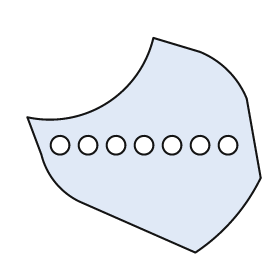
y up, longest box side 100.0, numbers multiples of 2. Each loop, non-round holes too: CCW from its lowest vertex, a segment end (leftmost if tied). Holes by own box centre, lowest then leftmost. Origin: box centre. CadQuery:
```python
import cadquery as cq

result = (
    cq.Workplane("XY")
    .moveTo(22.0, -46.0)
    .threePointArc((38.0, -32.0), (50.0, -14.0))
    .lineTo(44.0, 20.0)
    .threePointArc((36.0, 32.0), (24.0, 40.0))
    .lineTo(4.0, 46.0)
    .threePointArc((-16.0, 18.0), (-50.0, 12.0))
    .lineTo(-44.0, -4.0)
    .threePointArc((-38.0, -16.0), (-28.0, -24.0))
    .close()
    .moveTo(-36.0, 0.0)
    .circle(4.0)
    .moveTo(-24.0, 0.0)
    .circle(4.0)
    .moveTo(-12.0, 0.0)
    .circle(4.0)
    .moveTo(0.0, 0.0)
    .circle(4.0)
    .moveTo(12.0, 0.0)
    .circle(4.0)
    .moveTo(24.0, 0.0)
    .circle(4.0)
    .moveTo(36.0, 0.0)
    .circle(4.0)
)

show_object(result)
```